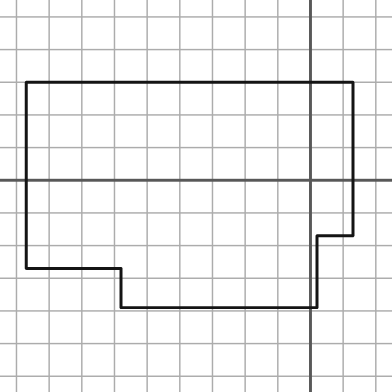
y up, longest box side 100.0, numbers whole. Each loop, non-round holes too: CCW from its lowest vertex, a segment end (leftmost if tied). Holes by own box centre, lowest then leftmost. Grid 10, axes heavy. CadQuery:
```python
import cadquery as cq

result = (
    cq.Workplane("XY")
    .moveTo(-58.0, -39.0)
    .lineTo(2.0, -39.0)
    .lineTo(2.0, -17.0)
    .lineTo(13.0, -17.0)
    .lineTo(13.0, 30.0)
    .lineTo(-87.0, 30.0)
    .lineTo(-87.0, -27.0)
    .lineTo(-58.0, -27.0)
    .close()
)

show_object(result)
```